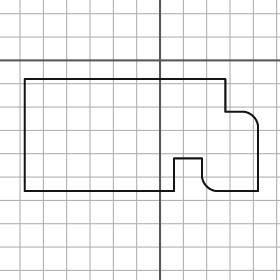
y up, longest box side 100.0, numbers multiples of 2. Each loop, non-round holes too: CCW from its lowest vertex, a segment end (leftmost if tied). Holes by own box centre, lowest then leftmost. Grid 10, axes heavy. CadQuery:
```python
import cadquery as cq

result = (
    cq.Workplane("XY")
    .moveTo(-58.0, -56.0)
    .lineTo(6.0, -56.0)
    .lineTo(6.0, -42.0)
    .lineTo(18.0, -42.0)
    .lineTo(18.0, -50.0)
    .threePointArc((20.0, -54.0), (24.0, -56.0))
    .lineTo(42.0, -56.0)
    .lineTo(42.0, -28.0)
    .threePointArc((40.0, -24.0), (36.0, -22.0))
    .lineTo(28.0, -22.0)
    .lineTo(28.0, -8.0)
    .lineTo(-58.0, -8.0)
    .close()
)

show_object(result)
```